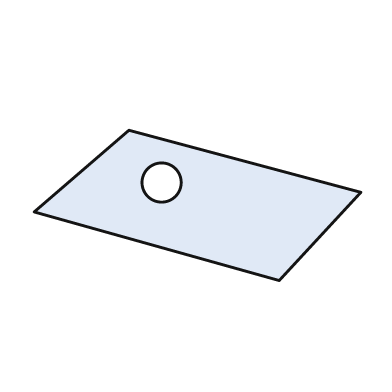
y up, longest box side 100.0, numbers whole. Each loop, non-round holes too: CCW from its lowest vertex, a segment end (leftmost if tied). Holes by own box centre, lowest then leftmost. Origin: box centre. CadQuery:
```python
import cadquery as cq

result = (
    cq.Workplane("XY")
    .moveTo(25.0, -23.0)
    .lineTo(50.0, 4.0)
    .lineTo(-21.0, 23.0)
    .lineTo(-50.0, -2.0)
    .close()
    .moveTo(-11.0, 7.0)
    .circle(6.0)
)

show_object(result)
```